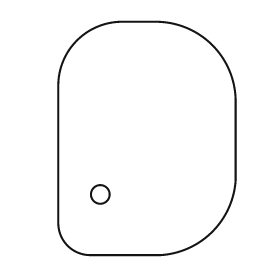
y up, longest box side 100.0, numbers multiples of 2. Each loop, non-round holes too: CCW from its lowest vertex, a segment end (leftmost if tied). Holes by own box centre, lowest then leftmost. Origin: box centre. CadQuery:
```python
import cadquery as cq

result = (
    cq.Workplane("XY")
    .moveTo(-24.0, -50.0)
    .lineTo(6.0, -50.0)
    .threePointArc((28.0, -40.0), (38.0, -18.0))
    .lineTo(38.0, 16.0)
    .threePointArc((28.0, 40.0), (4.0, 50.0))
    .lineTo(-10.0, 50.0)
    .threePointArc((-30.0, 42.0), (-38.0, 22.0))
    .lineTo(-38.0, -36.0)
    .threePointArc((-34.0, -46.0), (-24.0, -50.0))
    .close()
    .moveTo(-20.0, -24.0)
    .circle(4.0)
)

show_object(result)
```